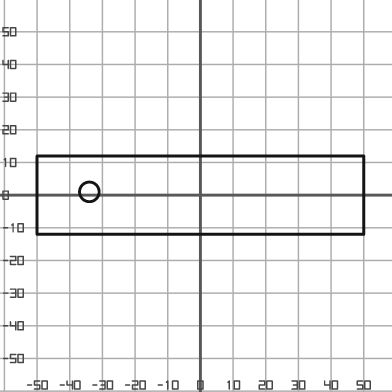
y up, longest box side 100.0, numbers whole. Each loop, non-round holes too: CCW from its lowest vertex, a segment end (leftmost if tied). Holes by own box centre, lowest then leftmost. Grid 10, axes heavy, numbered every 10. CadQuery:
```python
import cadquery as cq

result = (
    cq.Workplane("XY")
    .moveTo(-50.0, -12.0)
    .lineTo(50.0, -12.0)
    .lineTo(50.0, 12.0)
    .lineTo(-50.0, 12.0)
    .close()
    .moveTo(-34.0, 1.0)
    .circle(3.0)
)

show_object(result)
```